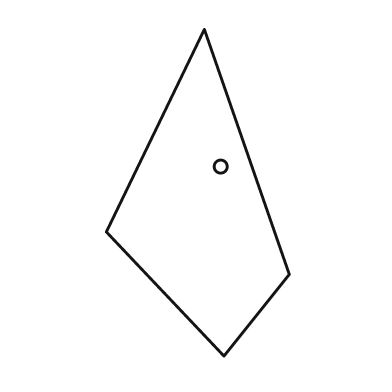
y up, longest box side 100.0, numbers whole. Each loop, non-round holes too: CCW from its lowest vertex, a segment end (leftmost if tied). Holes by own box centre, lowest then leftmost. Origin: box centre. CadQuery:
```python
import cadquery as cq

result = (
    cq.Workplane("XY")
    .moveTo(8.0, -50.0)
    .lineTo(28.0, -25.0)
    .lineTo(2.0, 50.0)
    .lineTo(-28.0, -12.0)
    .close()
    .moveTo(7.0, 8.0)
    .circle(2.0)
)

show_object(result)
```